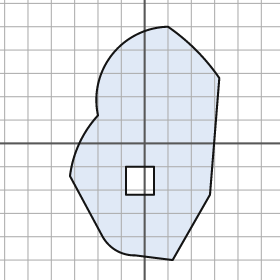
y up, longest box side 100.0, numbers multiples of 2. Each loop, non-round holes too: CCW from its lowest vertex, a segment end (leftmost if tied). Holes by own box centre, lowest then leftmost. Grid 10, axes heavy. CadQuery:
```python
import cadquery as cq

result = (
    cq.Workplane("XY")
    .moveTo(12.0, -50.0)
    .lineTo(28.0, -22.0)
    .lineTo(32.0, 28.0)
    .threePointArc((22.0, 40.0), (10.0, 50.0))
    .threePointArc((-14.0, 38.0), (-20.0, 12.0))
    .threePointArc((-28.0, 0.0), (-32.0, -14.0))
    .lineTo(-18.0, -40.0)
    .threePointArc((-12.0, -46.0), (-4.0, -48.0))
    .close()
    .moveTo(-8.0, -22.0)
    .lineTo(4.0, -22.0)
    .lineTo(4.0, -10.0)
    .lineTo(-8.0, -10.0)
    .close()
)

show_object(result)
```